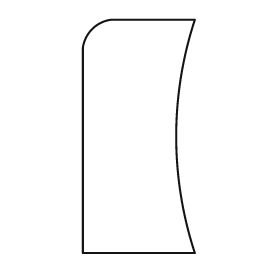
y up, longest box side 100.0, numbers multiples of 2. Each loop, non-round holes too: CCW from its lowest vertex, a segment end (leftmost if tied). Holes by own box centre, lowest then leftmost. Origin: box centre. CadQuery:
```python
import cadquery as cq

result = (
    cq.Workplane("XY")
    .moveTo(-24.0, -50.0)
    .lineTo(24.0, -50.0)
    .threePointArc((16.0, 0.0), (24.0, 50.0))
    .lineTo(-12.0, 50.0)
    .threePointArc((-20.0, 46.0), (-24.0, 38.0))
    .close()
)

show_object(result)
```